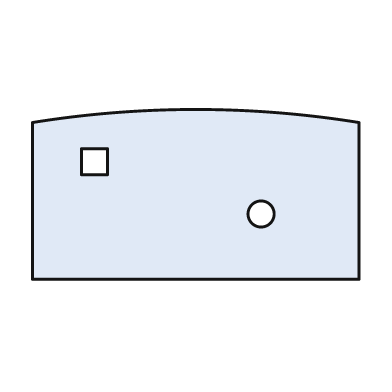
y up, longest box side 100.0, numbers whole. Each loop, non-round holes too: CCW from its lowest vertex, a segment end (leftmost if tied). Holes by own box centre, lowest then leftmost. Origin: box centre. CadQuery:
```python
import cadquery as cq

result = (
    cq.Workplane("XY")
    .moveTo(-50.0, -26.0)
    .lineTo(50.0, -26.0)
    .lineTo(50.0, 22.0)
    .threePointArc((0.0, 26.0), (-50.0, 22.0))
    .close()
    .moveTo(20.0, -6.0)
    .circle(4.0)
    .moveTo(-35.0, 6.0)
    .lineTo(-27.0, 6.0)
    .lineTo(-27.0, 14.0)
    .lineTo(-35.0, 14.0)
    .close()
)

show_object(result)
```